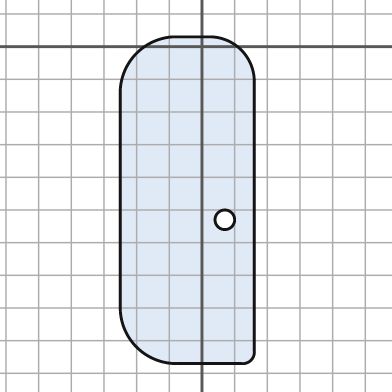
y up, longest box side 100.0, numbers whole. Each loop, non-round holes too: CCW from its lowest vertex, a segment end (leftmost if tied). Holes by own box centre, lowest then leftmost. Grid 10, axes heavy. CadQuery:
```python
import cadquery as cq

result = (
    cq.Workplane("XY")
    .moveTo(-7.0, -97.0)
    .lineTo(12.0, -97.0)
    .threePointArc((15.0, -96.0), (16.0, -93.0))
    .lineTo(16.0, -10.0)
    .threePointArc((12.0, -1.0), (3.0, 3.0))
    .lineTo(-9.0, 3.0)
    .threePointArc((-20.0, -2.0), (-25.0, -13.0))
    .lineTo(-25.0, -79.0)
    .threePointArc((-20.0, -92.0), (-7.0, -97.0))
    .close()
    .moveTo(7.0, -53.0)
    .circle(3.0)
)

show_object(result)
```